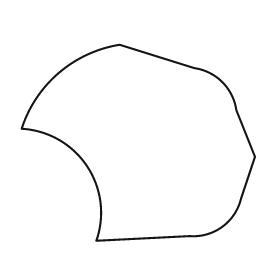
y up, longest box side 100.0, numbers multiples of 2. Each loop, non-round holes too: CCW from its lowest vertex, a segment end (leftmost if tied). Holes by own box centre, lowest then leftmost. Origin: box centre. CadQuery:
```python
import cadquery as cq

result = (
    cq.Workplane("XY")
    .moveTo(-18.0, -42.0)
    .lineTo(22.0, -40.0)
    .threePointArc((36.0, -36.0), (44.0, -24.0))
    .lineTo(50.0, -6.0)
    .lineTo(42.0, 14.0)
    .threePointArc((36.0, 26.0), (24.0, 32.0))
    .lineTo(-8.0, 42.0)
    .threePointArc((-34.0, 30.0), (-50.0, 6.0))
    .threePointArc((-22.0, -10.0), (-18.0, -42.0))
    .close()
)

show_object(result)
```